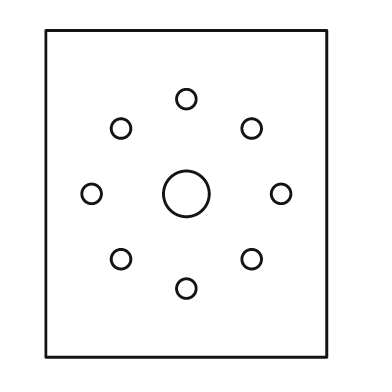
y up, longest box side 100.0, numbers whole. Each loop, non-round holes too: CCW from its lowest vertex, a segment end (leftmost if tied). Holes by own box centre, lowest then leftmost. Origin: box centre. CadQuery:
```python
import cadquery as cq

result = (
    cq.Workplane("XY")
    .moveTo(-43.0, -50.0)
    .lineTo(43.0, -50.0)
    .lineTo(43.0, 50.0)
    .lineTo(-43.0, 50.0)
    .close()
    .moveTo(0.0, -29.0)
    .circle(3.0)
    .moveTo(-20.0, -20.0)
    .circle(3.0)
    .moveTo(20.0, -20.0)
    .circle(3.0)
    .moveTo(-29.0, 0.0)
    .circle(3.0)
    .moveTo(0.0, 0.0)
    .circle(7.0)
    .moveTo(29.0, 0.0)
    .circle(3.0)
    .moveTo(-20.0, 20.0)
    .circle(3.0)
    .moveTo(20.0, 20.0)
    .circle(3.0)
    .moveTo(0.0, 29.0)
    .circle(3.0)
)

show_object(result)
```